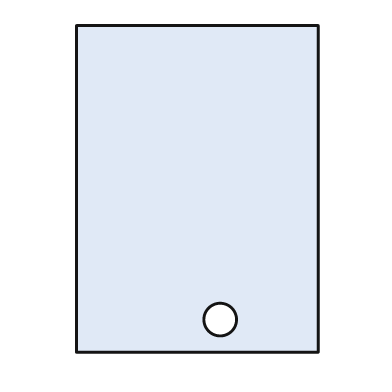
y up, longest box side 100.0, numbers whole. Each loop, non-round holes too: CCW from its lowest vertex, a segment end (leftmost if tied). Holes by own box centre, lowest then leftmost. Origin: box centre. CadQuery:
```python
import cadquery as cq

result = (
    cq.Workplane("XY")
    .moveTo(-37.0, -50.0)
    .lineTo(37.0, -50.0)
    .lineTo(37.0, 50.0)
    .lineTo(-37.0, 50.0)
    .close()
    .moveTo(7.0, -40.0)
    .circle(5.0)
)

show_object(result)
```